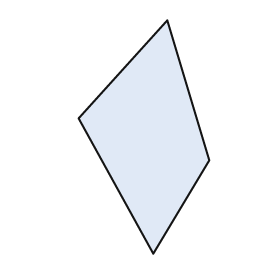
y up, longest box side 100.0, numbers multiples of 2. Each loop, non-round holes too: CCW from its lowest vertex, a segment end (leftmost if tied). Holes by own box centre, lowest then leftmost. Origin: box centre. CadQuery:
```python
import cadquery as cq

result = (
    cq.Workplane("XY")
    .moveTo(4.0, -50.0)
    .lineTo(28.0, -10.0)
    .lineTo(10.0, 50.0)
    .lineTo(-28.0, 8.0)
    .close()
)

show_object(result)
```